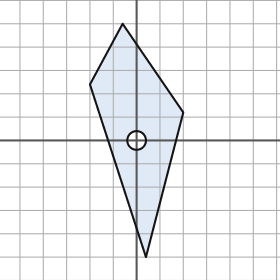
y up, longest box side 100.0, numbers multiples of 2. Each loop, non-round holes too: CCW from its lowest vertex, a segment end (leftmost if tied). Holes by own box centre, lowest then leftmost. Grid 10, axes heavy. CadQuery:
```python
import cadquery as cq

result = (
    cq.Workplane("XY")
    .moveTo(4.0, -50.0)
    .lineTo(20.0, 12.0)
    .lineTo(-6.0, 50.0)
    .lineTo(-20.0, 24.0)
    .close()
    .moveTo(0.0, 0.0)
    .circle(4.0)
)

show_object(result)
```